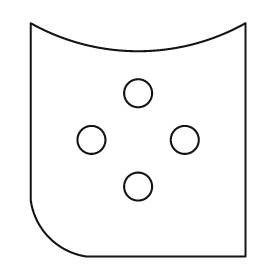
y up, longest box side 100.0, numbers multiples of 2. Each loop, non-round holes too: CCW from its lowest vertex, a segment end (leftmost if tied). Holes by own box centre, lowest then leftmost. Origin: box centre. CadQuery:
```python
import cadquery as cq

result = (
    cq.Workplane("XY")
    .moveTo(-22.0, -50.0)
    .lineTo(46.0, -50.0)
    .lineTo(46.0, 50.0)
    .threePointArc((0.0, 38.0), (-46.0, 50.0))
    .lineTo(-46.0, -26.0)
    .threePointArc((-38.0, -42.0), (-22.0, -50.0))
    .close()
    .moveTo(0.0, -20.0)
    .circle(6.0)
    .moveTo(-20.0, 0.0)
    .circle(6.0)
    .moveTo(20.0, 0.0)
    .circle(6.0)
    .moveTo(0.0, 20.0)
    .circle(6.0)
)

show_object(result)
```